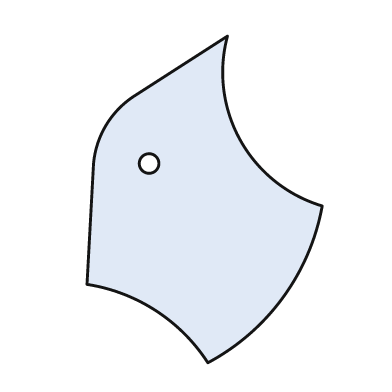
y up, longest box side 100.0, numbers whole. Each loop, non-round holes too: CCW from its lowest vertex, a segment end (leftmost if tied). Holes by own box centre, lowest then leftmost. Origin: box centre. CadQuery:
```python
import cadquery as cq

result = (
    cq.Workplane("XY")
    .moveTo(1.0, -50.0)
    .threePointArc((24.0, -30.0), (36.0, -2.0))
    .threePointArc((11.0, 18.0), (7.0, 50.0))
    .lineTo(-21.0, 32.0)
    .threePointArc((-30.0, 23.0), (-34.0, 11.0))
    .lineTo(-36.0, -26.0)
    .threePointArc((-15.0, -34.0), (1.0, -50.0))
    .close()
    .moveTo(-17.0, 11.0)
    .circle(3.0)
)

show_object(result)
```